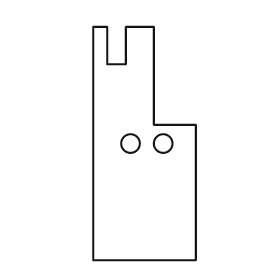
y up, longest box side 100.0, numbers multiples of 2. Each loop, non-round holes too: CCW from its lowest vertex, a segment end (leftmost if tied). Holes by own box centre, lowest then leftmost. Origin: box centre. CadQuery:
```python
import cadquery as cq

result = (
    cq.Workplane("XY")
    .moveTo(-22.0, -50.0)
    .lineTo(22.0, -50.0)
    .lineTo(22.0, 8.0)
    .lineTo(4.0, 8.0)
    .lineTo(4.0, 50.0)
    .lineTo(-8.0, 50.0)
    .lineTo(-8.0, 34.0)
    .lineTo(-16.0, 34.0)
    .lineTo(-16.0, 50.0)
    .lineTo(-22.0, 50.0)
    .close()
    .moveTo(-6.0, 0.0)
    .circle(4.0)
    .moveTo(8.0, 0.0)
    .circle(4.0)
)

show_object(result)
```